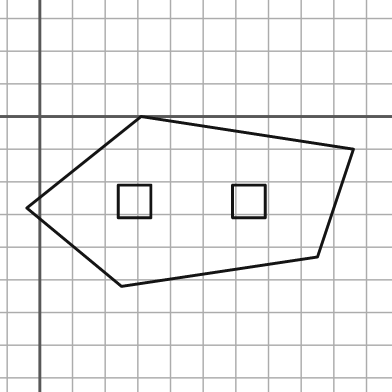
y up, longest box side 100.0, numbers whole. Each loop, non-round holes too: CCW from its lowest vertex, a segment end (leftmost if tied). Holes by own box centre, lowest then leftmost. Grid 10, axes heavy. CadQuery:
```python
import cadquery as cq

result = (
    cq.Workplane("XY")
    .moveTo(25.0, -52.0)
    .lineTo(85.0, -43.0)
    .lineTo(96.0, -10.0)
    .lineTo(31.0, 0.0)
    .lineTo(-4.0, -28.0)
    .close()
    .moveTo(24.0, -31.0)
    .lineTo(34.0, -31.0)
    .lineTo(34.0, -21.0)
    .lineTo(24.0, -21.0)
    .close()
    .moveTo(59.0, -31.0)
    .lineTo(69.0, -31.0)
    .lineTo(69.0, -21.0)
    .lineTo(59.0, -21.0)
    .close()
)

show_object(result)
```